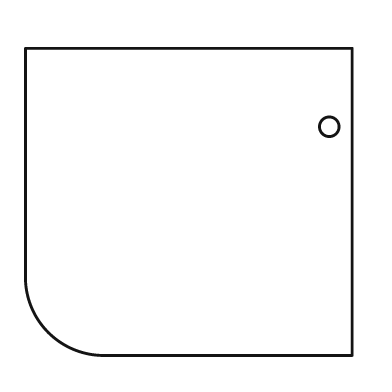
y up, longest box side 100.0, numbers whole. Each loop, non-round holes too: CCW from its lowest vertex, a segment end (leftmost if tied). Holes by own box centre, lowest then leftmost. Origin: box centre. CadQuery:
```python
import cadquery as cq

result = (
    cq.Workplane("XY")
    .moveTo(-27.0, -47.0)
    .lineTo(50.0, -47.0)
    .lineTo(50.0, 47.0)
    .lineTo(-50.0, 47.0)
    .lineTo(-50.0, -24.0)
    .threePointArc((-43.0, -40.0), (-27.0, -47.0))
    .close()
    .moveTo(43.0, 23.0)
    .circle(3.0)
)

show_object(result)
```